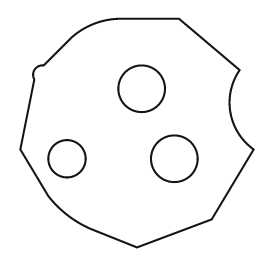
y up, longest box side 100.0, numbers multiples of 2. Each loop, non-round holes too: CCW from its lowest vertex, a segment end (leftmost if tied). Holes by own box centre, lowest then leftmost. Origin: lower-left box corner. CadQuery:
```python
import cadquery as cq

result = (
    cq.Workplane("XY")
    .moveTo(50.0, 0.0)
    .lineTo(82.0, 12.0)
    .lineTo(100.0, 42.0)
    .threePointArc((90.0, 58.0), (94.0, 76.0))
    .lineTo(68.0, 98.0)
    .lineTo(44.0, 98.0)
    .threePointArc((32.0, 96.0), (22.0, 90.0))
    .lineTo(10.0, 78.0)
    .threePointArc((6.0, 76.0), (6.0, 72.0))
    .lineTo(0.0, 42.0)
    .lineTo(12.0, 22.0)
    .threePointArc((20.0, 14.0), (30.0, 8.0))
    .close()
    .moveTo(20.0, 38.0)
    .circle(8.0)
    .moveTo(66.0, 38.0)
    .circle(10.0)
    .moveTo(52.0, 68.0)
    .circle(10.0)
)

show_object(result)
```